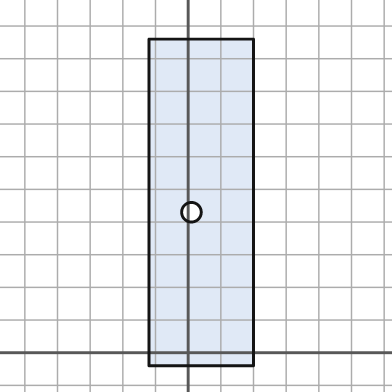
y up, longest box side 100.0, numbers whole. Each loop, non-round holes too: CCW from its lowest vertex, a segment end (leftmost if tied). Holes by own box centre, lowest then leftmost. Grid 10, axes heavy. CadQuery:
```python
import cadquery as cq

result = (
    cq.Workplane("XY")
    .moveTo(-12.0, -4.0)
    .lineTo(20.0, -4.0)
    .lineTo(20.0, 96.0)
    .lineTo(-12.0, 96.0)
    .close()
    .moveTo(1.0, 43.0)
    .circle(3.0)
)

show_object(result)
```